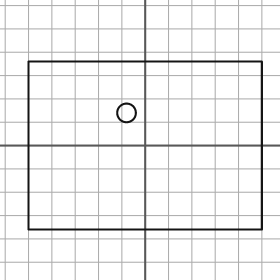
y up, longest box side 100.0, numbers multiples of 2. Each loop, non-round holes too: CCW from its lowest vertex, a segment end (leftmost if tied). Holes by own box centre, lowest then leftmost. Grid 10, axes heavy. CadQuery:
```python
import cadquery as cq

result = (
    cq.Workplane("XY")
    .moveTo(-50.0, -36.0)
    .lineTo(50.0, -36.0)
    .lineTo(50.0, 36.0)
    .lineTo(-50.0, 36.0)
    .close()
    .moveTo(-8.0, 14.0)
    .circle(4.0)
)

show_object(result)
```